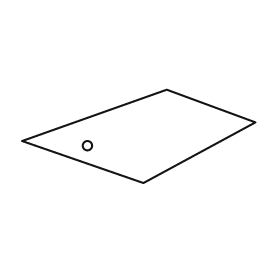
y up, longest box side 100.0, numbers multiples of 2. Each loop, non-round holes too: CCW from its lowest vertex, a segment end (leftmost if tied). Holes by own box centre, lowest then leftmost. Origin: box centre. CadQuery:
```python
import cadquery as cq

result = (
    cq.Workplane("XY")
    .moveTo(2.0, -20.0)
    .lineTo(50.0, 6.0)
    .lineTo(12.0, 20.0)
    .lineTo(-50.0, -2.0)
    .close()
    .moveTo(-22.0, -4.0)
    .circle(2.0)
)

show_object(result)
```